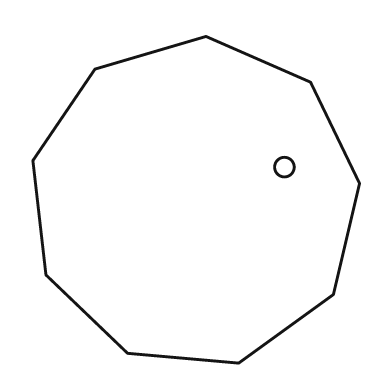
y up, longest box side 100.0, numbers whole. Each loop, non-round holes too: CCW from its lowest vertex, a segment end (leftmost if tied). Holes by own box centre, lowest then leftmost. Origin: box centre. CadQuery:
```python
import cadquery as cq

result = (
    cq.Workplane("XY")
    .moveTo(13.0, -50.0)
    .lineTo(42.0, -29.0)
    .lineTo(50.0, 5.0)
    .lineTo(35.0, 36.0)
    .lineTo(3.0, 50.0)
    .lineTo(-31.0, 40.0)
    .lineTo(-50.0, 12.0)
    .lineTo(-46.0, -23.0)
    .lineTo(-21.0, -47.0)
    .close()
    .moveTo(27.0, 10.0)
    .circle(3.0)
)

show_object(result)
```